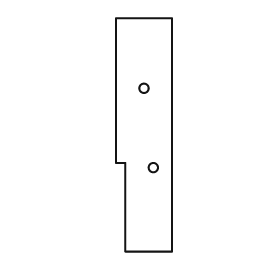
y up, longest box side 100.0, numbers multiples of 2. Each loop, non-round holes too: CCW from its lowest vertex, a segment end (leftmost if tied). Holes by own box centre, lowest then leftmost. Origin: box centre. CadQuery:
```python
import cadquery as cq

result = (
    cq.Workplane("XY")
    .moveTo(-8.0, -50.0)
    .lineTo(12.0, -50.0)
    .lineTo(12.0, 50.0)
    .lineTo(-12.0, 50.0)
    .lineTo(-12.0, -12.0)
    .lineTo(-8.0, -12.0)
    .close()
    .moveTo(4.0, -14.0)
    .circle(2.0)
    .moveTo(0.0, 20.0)
    .circle(2.0)
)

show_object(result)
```